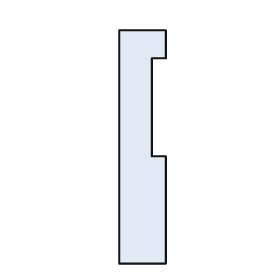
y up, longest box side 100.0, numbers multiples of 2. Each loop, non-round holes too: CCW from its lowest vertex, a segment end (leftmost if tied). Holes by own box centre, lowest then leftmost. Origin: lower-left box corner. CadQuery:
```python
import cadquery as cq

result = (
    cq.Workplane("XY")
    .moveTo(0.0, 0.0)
    .lineTo(20.0, 0.0)
    .lineTo(20.0, 46.0)
    .lineTo(14.0, 46.0)
    .lineTo(14.0, 88.0)
    .lineTo(20.0, 88.0)
    .lineTo(20.0, 100.0)
    .lineTo(0.0, 100.0)
    .close()
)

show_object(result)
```